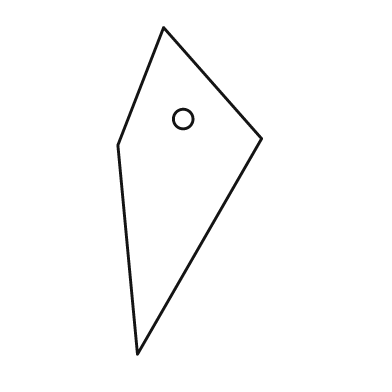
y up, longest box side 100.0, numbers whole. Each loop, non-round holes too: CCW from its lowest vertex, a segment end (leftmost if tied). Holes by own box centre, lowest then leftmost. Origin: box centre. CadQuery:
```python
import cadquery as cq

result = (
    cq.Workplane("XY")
    .moveTo(-16.0, -50.0)
    .lineTo(22.0, 16.0)
    .lineTo(-8.0, 50.0)
    .lineTo(-22.0, 14.0)
    .close()
    .moveTo(-2.0, 22.0)
    .circle(3.0)
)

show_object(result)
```